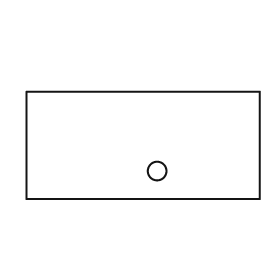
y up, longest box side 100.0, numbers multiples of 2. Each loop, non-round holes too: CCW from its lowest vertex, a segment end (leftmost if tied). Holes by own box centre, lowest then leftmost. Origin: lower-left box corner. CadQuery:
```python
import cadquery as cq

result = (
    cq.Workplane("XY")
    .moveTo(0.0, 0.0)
    .lineTo(100.0, 0.0)
    .lineTo(100.0, 46.0)
    .lineTo(0.0, 46.0)
    .close()
    .moveTo(56.0, 12.0)
    .circle(4.0)
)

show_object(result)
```